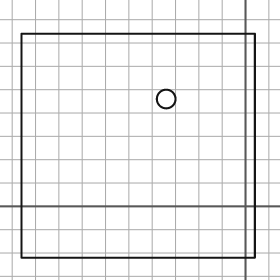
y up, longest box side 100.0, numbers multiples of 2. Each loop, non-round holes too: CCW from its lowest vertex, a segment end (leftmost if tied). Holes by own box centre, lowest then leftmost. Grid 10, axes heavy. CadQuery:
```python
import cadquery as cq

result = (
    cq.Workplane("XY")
    .moveTo(-96.0, -22.0)
    .lineTo(4.0, -22.0)
    .lineTo(4.0, 74.0)
    .lineTo(-96.0, 74.0)
    .close()
    .moveTo(-34.0, 46.0)
    .circle(4.0)
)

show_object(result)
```